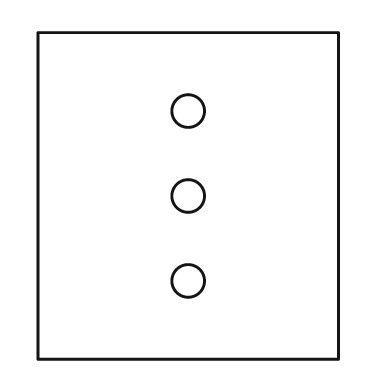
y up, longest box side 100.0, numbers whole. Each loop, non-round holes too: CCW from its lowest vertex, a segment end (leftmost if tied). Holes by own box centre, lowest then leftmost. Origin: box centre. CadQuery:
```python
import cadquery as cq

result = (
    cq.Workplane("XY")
    .moveTo(-46.0, -50.0)
    .lineTo(46.0, -50.0)
    .lineTo(46.0, 50.0)
    .lineTo(-46.0, 50.0)
    .close()
    .moveTo(0.0, -26.0)
    .circle(5.0)
    .moveTo(0.0, 0.0)
    .circle(5.0)
    .moveTo(0.0, 26.0)
    .circle(5.0)
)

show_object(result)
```